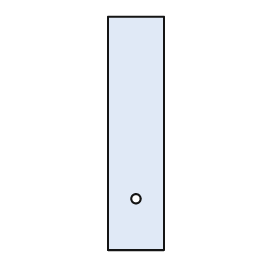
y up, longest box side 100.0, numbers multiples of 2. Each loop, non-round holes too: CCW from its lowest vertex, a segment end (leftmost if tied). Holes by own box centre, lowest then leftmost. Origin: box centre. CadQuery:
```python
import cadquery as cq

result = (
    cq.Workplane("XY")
    .moveTo(-12.0, -50.0)
    .lineTo(12.0, -50.0)
    .lineTo(12.0, 50.0)
    .lineTo(-12.0, 50.0)
    .close()
    .moveTo(0.0, -28.0)
    .circle(2.0)
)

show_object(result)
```